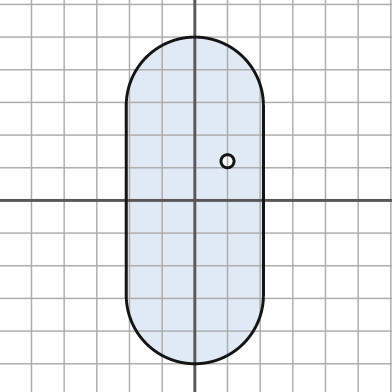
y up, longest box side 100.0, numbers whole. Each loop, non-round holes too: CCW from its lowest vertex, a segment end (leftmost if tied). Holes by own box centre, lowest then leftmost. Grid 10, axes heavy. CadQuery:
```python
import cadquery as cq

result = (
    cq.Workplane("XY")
    .moveTo(-21.0, -29.0)
    .threePointArc((0.0, -50.0), (21.0, -29.0))
    .lineTo(21.0, 29.0)
    .threePointArc((0.0, 50.0), (-21.0, 29.0))
    .close()
    .moveTo(10.0, 12.0)
    .circle(2.0)
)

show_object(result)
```